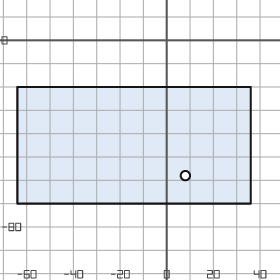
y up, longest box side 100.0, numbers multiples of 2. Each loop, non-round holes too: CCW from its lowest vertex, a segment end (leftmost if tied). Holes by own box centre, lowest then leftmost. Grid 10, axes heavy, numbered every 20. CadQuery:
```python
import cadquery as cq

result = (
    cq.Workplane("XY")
    .moveTo(-64.0, -70.0)
    .lineTo(36.0, -70.0)
    .lineTo(36.0, -20.0)
    .lineTo(-64.0, -20.0)
    .close()
    .moveTo(8.0, -58.0)
    .circle(2.0)
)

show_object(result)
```